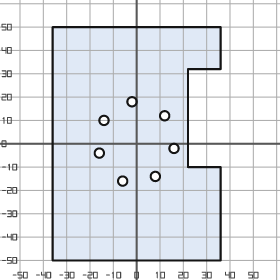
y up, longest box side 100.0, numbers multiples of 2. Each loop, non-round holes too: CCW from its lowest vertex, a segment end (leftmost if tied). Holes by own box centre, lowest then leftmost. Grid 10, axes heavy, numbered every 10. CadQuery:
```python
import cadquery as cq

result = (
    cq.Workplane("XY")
    .moveTo(-36.0, -50.0)
    .lineTo(36.0, -50.0)
    .lineTo(36.0, -10.0)
    .lineTo(22.0, -10.0)
    .lineTo(22.0, 32.0)
    .lineTo(36.0, 32.0)
    .lineTo(36.0, 50.0)
    .lineTo(-36.0, 50.0)
    .close()
    .moveTo(-6.0, -16.0)
    .circle(2.0)
    .moveTo(8.0, -14.0)
    .circle(2.0)
    .moveTo(-16.0, -4.0)
    .circle(2.0)
    .moveTo(16.0, -2.0)
    .circle(2.0)
    .moveTo(-14.0, 10.0)
    .circle(2.0)
    .moveTo(12.0, 12.0)
    .circle(2.0)
    .moveTo(-2.0, 18.0)
    .circle(2.0)
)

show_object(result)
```